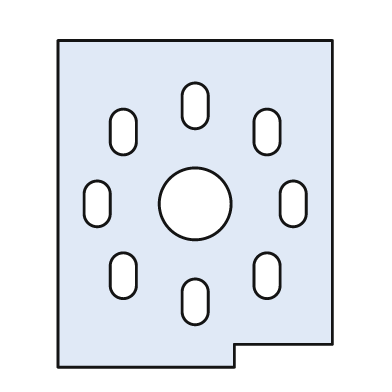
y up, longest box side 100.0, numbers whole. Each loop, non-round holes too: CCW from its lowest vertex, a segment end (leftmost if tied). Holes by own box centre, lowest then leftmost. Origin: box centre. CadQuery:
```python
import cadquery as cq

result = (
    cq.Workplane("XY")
    .moveTo(-42.0, -50.0)
    .lineTo(12.0, -50.0)
    .lineTo(12.0, -43.0)
    .lineTo(42.0, -43.0)
    .lineTo(42.0, 50.0)
    .lineTo(-42.0, 50.0)
    .close()
    .moveTo(-4.0, -33.0)
    .threePointArc((0.0, -37.0), (4.0, -33.0))
    .lineTo(4.0, -27.0)
    .threePointArc((0.0, -23.0), (-4.0, -27.0))
    .close()
    .moveTo(-26.0, -25.0)
    .threePointArc((-22.0, -29.0), (-18.0, -25.0))
    .lineTo(-18.0, -19.0)
    .threePointArc((-22.0, -15.0), (-26.0, -19.0))
    .close()
    .moveTo(18.0, -25.0)
    .threePointArc((22.0, -29.0), (26.0, -25.0))
    .lineTo(26.0, -19.0)
    .threePointArc((22.0, -15.0), (18.0, -19.0))
    .close()
    .moveTo(-34.0, -3.0)
    .threePointArc((-30.0, -7.0), (-26.0, -3.0))
    .lineTo(-26.0, 3.0)
    .threePointArc((-30.0, 7.0), (-34.0, 3.0))
    .close()
    .moveTo(0.0, 0.0)
    .circle(11.0)
    .moveTo(26.0, -3.0)
    .threePointArc((30.0, -7.0), (34.0, -3.0))
    .lineTo(34.0, 3.0)
    .threePointArc((30.0, 7.0), (26.0, 3.0))
    .close()
    .moveTo(-26.0, 19.0)
    .threePointArc((-22.0, 15.0), (-18.0, 19.0))
    .lineTo(-18.0, 25.0)
    .threePointArc((-22.0, 29.0), (-26.0, 25.0))
    .close()
    .moveTo(18.0, 19.0)
    .threePointArc((22.0, 15.0), (26.0, 19.0))
    .lineTo(26.0, 25.0)
    .threePointArc((22.0, 29.0), (18.0, 25.0))
    .close()
    .moveTo(-4.0, 27.0)
    .threePointArc((0.0, 23.0), (4.0, 27.0))
    .lineTo(4.0, 33.0)
    .threePointArc((0.0, 37.0), (-4.0, 33.0))
    .close()
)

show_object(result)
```